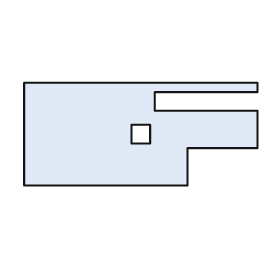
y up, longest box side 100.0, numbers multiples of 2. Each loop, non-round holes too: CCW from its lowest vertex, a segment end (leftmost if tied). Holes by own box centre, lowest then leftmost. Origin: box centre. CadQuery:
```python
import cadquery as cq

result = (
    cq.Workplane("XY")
    .moveTo(-50.0, -22.0)
    .lineTo(20.0, -22.0)
    .lineTo(20.0, -6.0)
    .lineTo(50.0, -6.0)
    .lineTo(50.0, 10.0)
    .lineTo(6.0, 10.0)
    .lineTo(6.0, 18.0)
    .lineTo(50.0, 18.0)
    .lineTo(50.0, 22.0)
    .lineTo(-50.0, 22.0)
    .close()
    .moveTo(-4.0, -4.0)
    .lineTo(4.0, -4.0)
    .lineTo(4.0, 4.0)
    .lineTo(-4.0, 4.0)
    .close()
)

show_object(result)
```